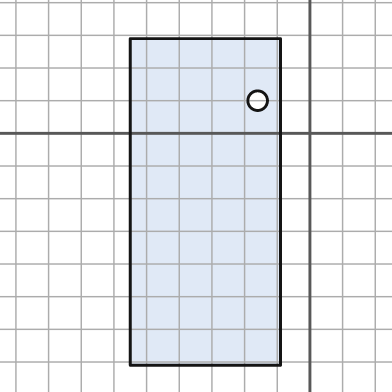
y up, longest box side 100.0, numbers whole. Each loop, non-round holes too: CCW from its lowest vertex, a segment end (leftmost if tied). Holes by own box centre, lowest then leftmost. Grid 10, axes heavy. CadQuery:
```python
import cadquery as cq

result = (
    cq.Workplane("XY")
    .moveTo(-55.0, -71.0)
    .lineTo(-9.0, -71.0)
    .lineTo(-9.0, 29.0)
    .lineTo(-55.0, 29.0)
    .close()
    .moveTo(-16.0, 10.0)
    .circle(3.0)
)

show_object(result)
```